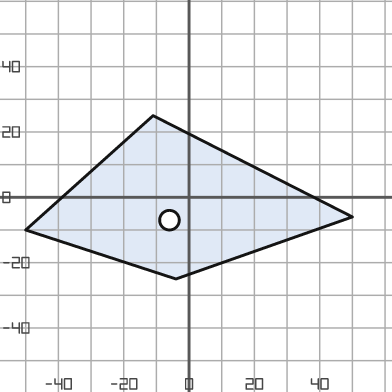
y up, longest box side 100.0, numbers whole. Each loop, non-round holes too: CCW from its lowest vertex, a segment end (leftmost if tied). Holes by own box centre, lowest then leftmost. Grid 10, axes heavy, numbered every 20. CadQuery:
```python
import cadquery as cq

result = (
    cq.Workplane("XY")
    .moveTo(-4.0, -25.0)
    .lineTo(50.0, -6.0)
    .lineTo(-11.0, 25.0)
    .lineTo(-50.0, -10.0)
    .close()
    .moveTo(-6.0, -7.0)
    .circle(3.0)
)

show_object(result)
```